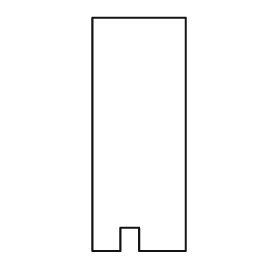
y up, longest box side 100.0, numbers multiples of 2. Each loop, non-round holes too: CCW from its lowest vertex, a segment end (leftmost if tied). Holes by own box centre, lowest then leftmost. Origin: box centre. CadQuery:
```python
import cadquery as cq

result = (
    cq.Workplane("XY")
    .moveTo(-20.0, -50.0)
    .lineTo(-8.0, -50.0)
    .lineTo(-8.0, -40.0)
    .lineTo(0.0, -40.0)
    .lineTo(0.0, -50.0)
    .lineTo(20.0, -50.0)
    .lineTo(20.0, 50.0)
    .lineTo(-20.0, 50.0)
    .close()
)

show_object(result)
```